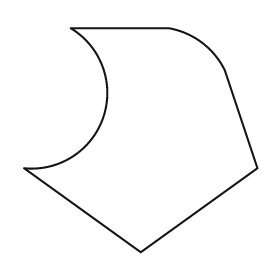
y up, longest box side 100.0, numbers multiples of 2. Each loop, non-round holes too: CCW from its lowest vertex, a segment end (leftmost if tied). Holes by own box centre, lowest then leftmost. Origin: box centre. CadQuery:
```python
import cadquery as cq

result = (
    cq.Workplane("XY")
    .moveTo(0.0, -48.0)
    .lineTo(50.0, -12.0)
    .lineTo(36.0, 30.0)
    .threePointArc((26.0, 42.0), (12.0, 48.0))
    .lineTo(-30.0, 48.0)
    .threePointArc((-16.0, 10.0), (-50.0, -12.0))
    .close()
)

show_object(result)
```